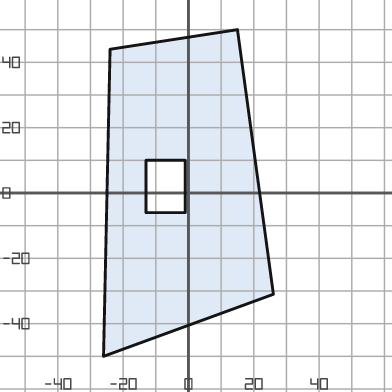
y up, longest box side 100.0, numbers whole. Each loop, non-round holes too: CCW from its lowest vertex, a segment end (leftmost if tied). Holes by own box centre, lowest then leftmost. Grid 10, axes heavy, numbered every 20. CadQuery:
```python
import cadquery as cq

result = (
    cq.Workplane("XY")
    .moveTo(-26.0, -50.0)
    .lineTo(26.0, -31.0)
    .lineTo(15.0, 50.0)
    .lineTo(-24.0, 44.0)
    .close()
    .moveTo(-13.0, -6.0)
    .lineTo(-1.0, -6.0)
    .lineTo(-1.0, 10.0)
    .lineTo(-13.0, 10.0)
    .close()
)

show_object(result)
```